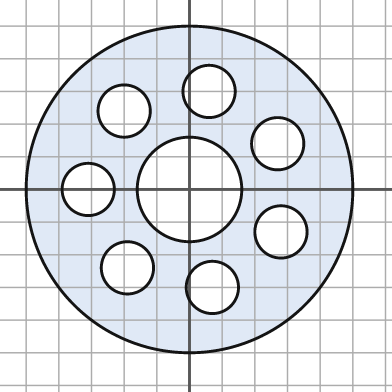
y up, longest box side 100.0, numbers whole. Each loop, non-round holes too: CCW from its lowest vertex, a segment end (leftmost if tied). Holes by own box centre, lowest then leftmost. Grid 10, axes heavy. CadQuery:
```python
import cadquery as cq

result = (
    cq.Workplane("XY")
    .moveTo(0.0, 0.0)
    .circle(50.0)
    .moveTo(7.0, -30.0)
    .circle(8.0)
    .moveTo(-19.0, -24.0)
    .circle(8.0)
    .moveTo(28.0, -13.0)
    .circle(8.0)
    .moveTo(-31.0, 0.0)
    .circle(8.0)
    .moveTo(0.0, 0.0)
    .circle(16.0)
    .moveTo(27.0, 14.0)
    .circle(8.0)
    .moveTo(-20.0, 24.0)
    .circle(8.0)
    .moveTo(6.0, 30.0)
    .circle(8.0)
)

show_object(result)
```